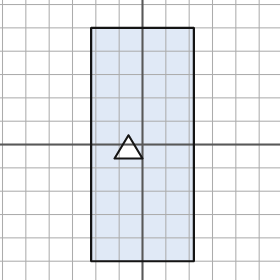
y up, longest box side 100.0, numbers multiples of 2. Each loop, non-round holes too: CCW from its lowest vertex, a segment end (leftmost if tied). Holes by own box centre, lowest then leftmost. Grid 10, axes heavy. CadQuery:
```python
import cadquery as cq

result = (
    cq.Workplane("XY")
    .moveTo(-22.0, -50.0)
    .lineTo(22.0, -50.0)
    .lineTo(22.0, 50.0)
    .lineTo(-22.0, 50.0)
    .close()
    .moveTo(-12.0, -6.0)
    .lineTo(0.0, -6.0)
    .lineTo(-6.0, 4.0)
    .close()
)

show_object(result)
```